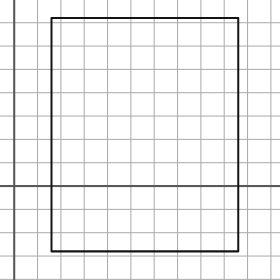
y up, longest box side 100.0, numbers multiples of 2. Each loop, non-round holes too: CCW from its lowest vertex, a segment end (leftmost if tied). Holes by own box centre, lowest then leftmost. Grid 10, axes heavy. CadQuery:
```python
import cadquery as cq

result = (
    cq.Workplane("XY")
    .moveTo(16.0, -28.0)
    .lineTo(96.0, -28.0)
    .lineTo(96.0, 72.0)
    .lineTo(16.0, 72.0)
    .close()
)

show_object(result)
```